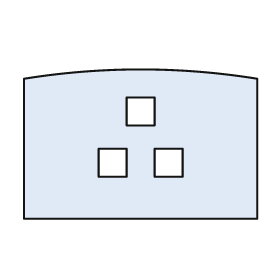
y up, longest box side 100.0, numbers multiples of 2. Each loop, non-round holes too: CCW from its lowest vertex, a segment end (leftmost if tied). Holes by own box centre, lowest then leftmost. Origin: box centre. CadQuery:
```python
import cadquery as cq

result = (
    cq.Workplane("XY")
    .moveTo(-50.0, -32.0)
    .lineTo(50.0, -32.0)
    .lineTo(50.0, 28.0)
    .threePointArc((0.0, 32.0), (-50.0, 28.0))
    .close()
    .moveTo(-18.0, -14.0)
    .lineTo(-6.0, -14.0)
    .lineTo(-6.0, -2.0)
    .lineTo(-18.0, -2.0)
    .close()
    .moveTo(6.0, -14.0)
    .lineTo(18.0, -14.0)
    .lineTo(18.0, -2.0)
    .lineTo(6.0, -2.0)
    .close()
    .moveTo(-6.0, 8.0)
    .lineTo(6.0, 8.0)
    .lineTo(6.0, 20.0)
    .lineTo(-6.0, 20.0)
    .close()
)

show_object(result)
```